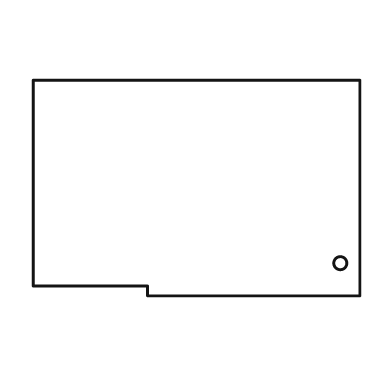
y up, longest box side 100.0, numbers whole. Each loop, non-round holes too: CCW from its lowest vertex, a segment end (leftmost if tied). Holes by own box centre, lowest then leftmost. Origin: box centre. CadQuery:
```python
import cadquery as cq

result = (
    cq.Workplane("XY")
    .moveTo(-15.0, -33.0)
    .lineTo(50.0, -33.0)
    .lineTo(50.0, 33.0)
    .lineTo(-50.0, 33.0)
    .lineTo(-50.0, -30.0)
    .lineTo(-15.0, -30.0)
    .close()
    .moveTo(44.0, -23.0)
    .circle(2.0)
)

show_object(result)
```